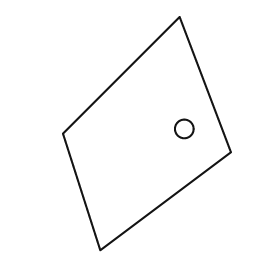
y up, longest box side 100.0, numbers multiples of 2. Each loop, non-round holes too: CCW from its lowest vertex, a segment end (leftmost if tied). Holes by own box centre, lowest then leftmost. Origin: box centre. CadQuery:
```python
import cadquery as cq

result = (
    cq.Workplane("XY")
    .moveTo(-20.0, -50.0)
    .lineTo(36.0, -8.0)
    .lineTo(14.0, 50.0)
    .lineTo(-36.0, 0.0)
    .close()
    .moveTo(16.0, 2.0)
    .circle(4.0)
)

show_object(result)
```